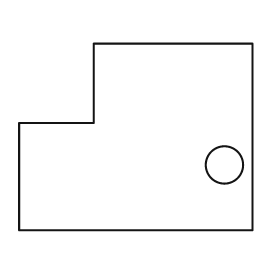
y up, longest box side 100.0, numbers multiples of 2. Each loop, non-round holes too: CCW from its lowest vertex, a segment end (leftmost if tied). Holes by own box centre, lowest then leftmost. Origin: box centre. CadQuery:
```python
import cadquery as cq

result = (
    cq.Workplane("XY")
    .moveTo(-50.0, -40.0)
    .lineTo(50.0, -40.0)
    .lineTo(50.0, 40.0)
    .lineTo(-18.0, 40.0)
    .lineTo(-18.0, 6.0)
    .lineTo(-50.0, 6.0)
    .close()
    .moveTo(38.0, -12.0)
    .circle(8.0)
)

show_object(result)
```